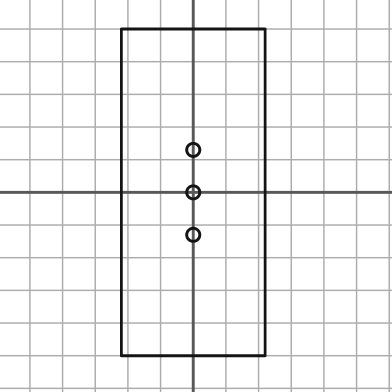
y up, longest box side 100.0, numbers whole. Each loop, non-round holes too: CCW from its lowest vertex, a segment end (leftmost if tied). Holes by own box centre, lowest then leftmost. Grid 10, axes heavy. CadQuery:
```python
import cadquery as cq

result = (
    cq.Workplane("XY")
    .moveTo(-22.0, -50.0)
    .lineTo(22.0, -50.0)
    .lineTo(22.0, 50.0)
    .lineTo(-22.0, 50.0)
    .close()
    .moveTo(0.0, -13.0)
    .circle(2.0)
    .moveTo(0.0, 0.0)
    .circle(2.0)
    .moveTo(0.0, 13.0)
    .circle(2.0)
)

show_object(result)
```